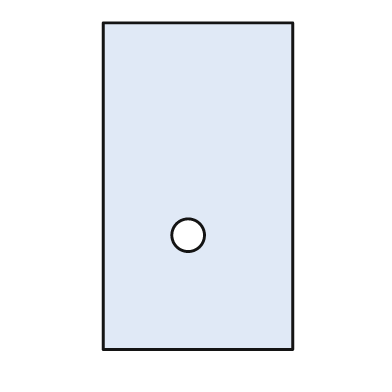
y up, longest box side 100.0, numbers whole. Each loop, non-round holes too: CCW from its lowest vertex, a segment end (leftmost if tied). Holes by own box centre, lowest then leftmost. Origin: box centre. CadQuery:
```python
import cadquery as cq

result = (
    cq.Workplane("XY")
    .moveTo(-29.0, -50.0)
    .lineTo(29.0, -50.0)
    .lineTo(29.0, 50.0)
    .lineTo(-29.0, 50.0)
    .close()
    .moveTo(-3.0, -15.0)
    .circle(5.0)
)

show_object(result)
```